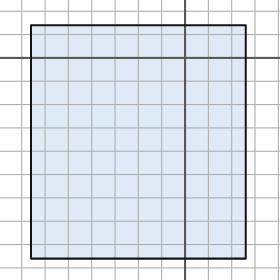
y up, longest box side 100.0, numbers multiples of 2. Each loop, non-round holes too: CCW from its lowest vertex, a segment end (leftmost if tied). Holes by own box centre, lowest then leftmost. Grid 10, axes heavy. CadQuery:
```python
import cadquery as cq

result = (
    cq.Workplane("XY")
    .moveTo(-66.0, -86.0)
    .lineTo(26.0, -86.0)
    .lineTo(26.0, 14.0)
    .lineTo(-66.0, 14.0)
    .close()
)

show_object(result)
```